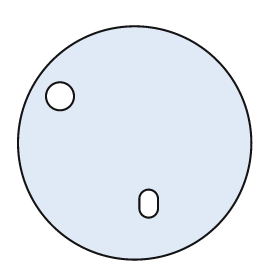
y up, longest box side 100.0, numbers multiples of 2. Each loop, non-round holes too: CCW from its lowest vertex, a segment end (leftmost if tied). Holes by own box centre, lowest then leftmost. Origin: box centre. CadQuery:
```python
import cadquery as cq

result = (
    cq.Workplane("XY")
    .moveTo(0.0, 0.0)
    .circle(50.0)
    .moveTo(2.0, -28.0)
    .threePointArc((6.0, -32.0), (10.0, -28.0))
    .lineTo(10.0, -24.0)
    .threePointArc((6.0, -20.0), (2.0, -24.0))
    .close()
    .moveTo(-32.0, 20.0)
    .circle(6.0)
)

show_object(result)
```